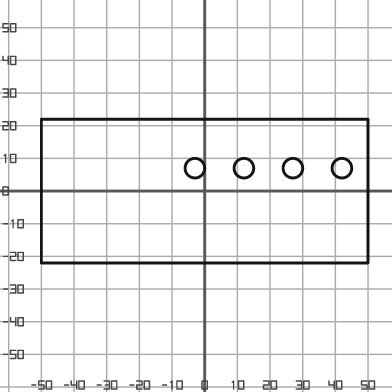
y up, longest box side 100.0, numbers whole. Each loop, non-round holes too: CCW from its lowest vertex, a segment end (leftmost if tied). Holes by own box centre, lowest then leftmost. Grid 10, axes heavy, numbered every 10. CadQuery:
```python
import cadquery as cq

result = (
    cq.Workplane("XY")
    .moveTo(-50.0, -22.0)
    .lineTo(50.0, -22.0)
    .lineTo(50.0, 22.0)
    .lineTo(-50.0, 22.0)
    .close()
    .moveTo(-3.0, 7.0)
    .circle(3.0)
    .moveTo(12.0, 7.0)
    .circle(3.0)
    .moveTo(27.0, 7.0)
    .circle(3.0)
    .moveTo(42.0, 7.0)
    .circle(3.0)
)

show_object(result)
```